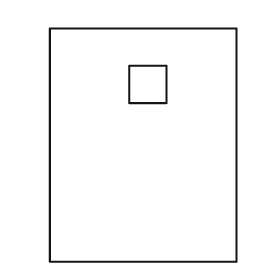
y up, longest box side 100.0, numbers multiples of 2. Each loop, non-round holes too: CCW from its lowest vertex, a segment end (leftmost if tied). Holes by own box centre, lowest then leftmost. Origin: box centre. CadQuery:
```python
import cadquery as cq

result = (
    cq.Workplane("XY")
    .moveTo(-40.0, -50.0)
    .lineTo(40.0, -50.0)
    .lineTo(40.0, 50.0)
    .lineTo(-40.0, 50.0)
    .close()
    .moveTo(-6.0, 18.0)
    .lineTo(10.0, 18.0)
    .lineTo(10.0, 34.0)
    .lineTo(-6.0, 34.0)
    .close()
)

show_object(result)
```